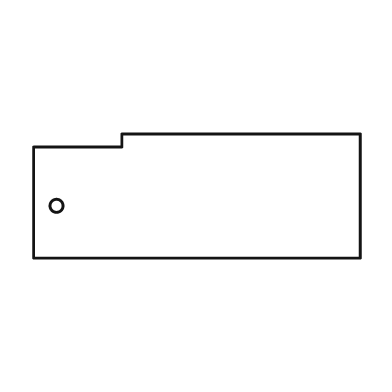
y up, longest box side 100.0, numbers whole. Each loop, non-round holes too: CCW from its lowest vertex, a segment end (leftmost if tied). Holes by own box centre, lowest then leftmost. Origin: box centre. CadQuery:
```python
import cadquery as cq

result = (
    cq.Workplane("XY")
    .moveTo(-50.0, -19.0)
    .lineTo(50.0, -19.0)
    .lineTo(50.0, 19.0)
    .lineTo(-23.0, 19.0)
    .lineTo(-23.0, 15.0)
    .lineTo(-50.0, 15.0)
    .close()
    .moveTo(-43.0, -3.0)
    .circle(2.0)
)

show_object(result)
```